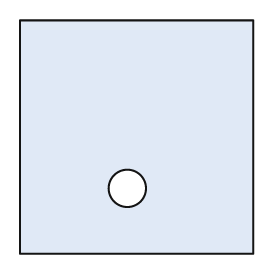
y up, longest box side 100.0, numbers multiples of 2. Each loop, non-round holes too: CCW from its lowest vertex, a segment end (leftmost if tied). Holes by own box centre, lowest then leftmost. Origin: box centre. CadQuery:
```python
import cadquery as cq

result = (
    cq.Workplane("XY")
    .moveTo(-50.0, -50.0)
    .lineTo(50.0, -50.0)
    .lineTo(50.0, 50.0)
    .lineTo(-50.0, 50.0)
    .close()
    .moveTo(-4.0, -22.0)
    .circle(8.0)
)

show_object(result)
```